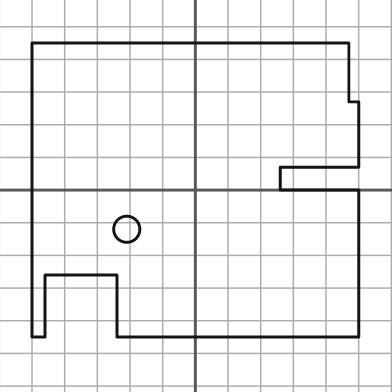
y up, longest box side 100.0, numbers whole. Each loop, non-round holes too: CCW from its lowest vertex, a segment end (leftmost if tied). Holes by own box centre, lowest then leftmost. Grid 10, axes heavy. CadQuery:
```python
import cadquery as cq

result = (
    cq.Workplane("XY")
    .moveTo(-50.0, -45.0)
    .lineTo(-46.0, -45.0)
    .lineTo(-46.0, -26.0)
    .lineTo(-24.0, -26.0)
    .lineTo(-24.0, -45.0)
    .lineTo(50.0, -45.0)
    .lineTo(50.0, 0.0)
    .lineTo(26.0, 0.0)
    .lineTo(26.0, 7.0)
    .lineTo(50.0, 7.0)
    .lineTo(50.0, 27.0)
    .lineTo(47.0, 27.0)
    .lineTo(47.0, 45.0)
    .lineTo(-50.0, 45.0)
    .close()
    .moveTo(-21.0, -12.0)
    .circle(4.0)
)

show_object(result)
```